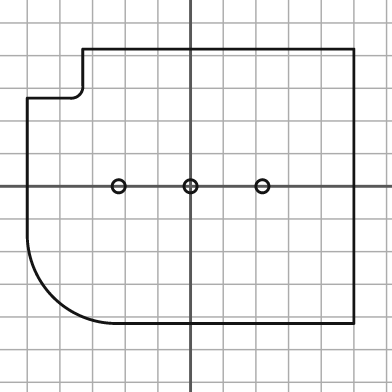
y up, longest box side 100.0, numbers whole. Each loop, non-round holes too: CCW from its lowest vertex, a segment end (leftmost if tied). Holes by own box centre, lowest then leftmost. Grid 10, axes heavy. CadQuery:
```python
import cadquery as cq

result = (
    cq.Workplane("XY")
    .moveTo(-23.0, -42.0)
    .lineTo(50.0, -42.0)
    .lineTo(50.0, 42.0)
    .lineTo(-33.0, 42.0)
    .lineTo(-33.0, 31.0)
    .threePointArc((-34.0, 28.0), (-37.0, 27.0))
    .lineTo(-50.0, 27.0)
    .lineTo(-50.0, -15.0)
    .threePointArc((-42.0, -34.0), (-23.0, -42.0))
    .close()
    .moveTo(-22.0, 0.0)
    .circle(2.0)
    .moveTo(0.0, 0.0)
    .circle(2.0)
    .moveTo(22.0, 0.0)
    .circle(2.0)
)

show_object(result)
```